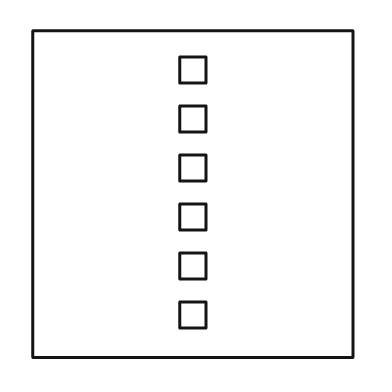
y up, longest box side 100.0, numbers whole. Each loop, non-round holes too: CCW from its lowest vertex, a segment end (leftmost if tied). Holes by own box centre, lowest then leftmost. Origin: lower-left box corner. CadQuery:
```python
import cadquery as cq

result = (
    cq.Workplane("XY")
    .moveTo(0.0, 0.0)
    .lineTo(98.0, 0.0)
    .lineTo(98.0, 100.0)
    .lineTo(0.0, 100.0)
    .close()
    .moveTo(45.0, 9.0)
    .lineTo(53.0, 9.0)
    .lineTo(53.0, 17.0)
    .lineTo(45.0, 17.0)
    .close()
    .moveTo(45.0, 24.0)
    .lineTo(53.0, 24.0)
    .lineTo(53.0, 32.0)
    .lineTo(45.0, 32.0)
    .close()
    .moveTo(45.0, 39.0)
    .lineTo(53.0, 39.0)
    .lineTo(53.0, 47.0)
    .lineTo(45.0, 47.0)
    .close()
    .moveTo(45.0, 54.0)
    .lineTo(53.0, 54.0)
    .lineTo(53.0, 62.0)
    .lineTo(45.0, 62.0)
    .close()
    .moveTo(45.0, 69.0)
    .lineTo(53.0, 69.0)
    .lineTo(53.0, 77.0)
    .lineTo(45.0, 77.0)
    .close()
    .moveTo(45.0, 84.0)
    .lineTo(53.0, 84.0)
    .lineTo(53.0, 92.0)
    .lineTo(45.0, 92.0)
    .close()
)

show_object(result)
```